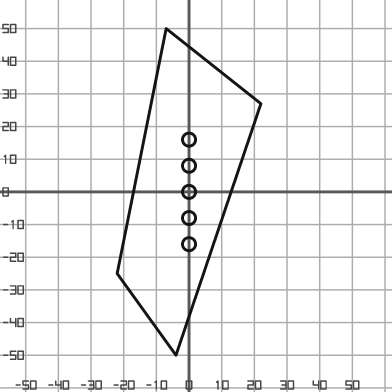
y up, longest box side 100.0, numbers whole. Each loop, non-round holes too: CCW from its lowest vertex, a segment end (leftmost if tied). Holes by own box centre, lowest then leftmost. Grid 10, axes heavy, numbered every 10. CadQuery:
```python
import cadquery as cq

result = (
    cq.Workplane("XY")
    .moveTo(-4.0, -50.0)
    .lineTo(22.0, 27.0)
    .lineTo(-7.0, 50.0)
    .lineTo(-22.0, -25.0)
    .close()
    .moveTo(0.0, -16.0)
    .circle(2.0)
    .moveTo(0.0, -8.0)
    .circle(2.0)
    .moveTo(0.0, 0.0)
    .circle(2.0)
    .moveTo(0.0, 8.0)
    .circle(2.0)
    .moveTo(0.0, 16.0)
    .circle(2.0)
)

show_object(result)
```